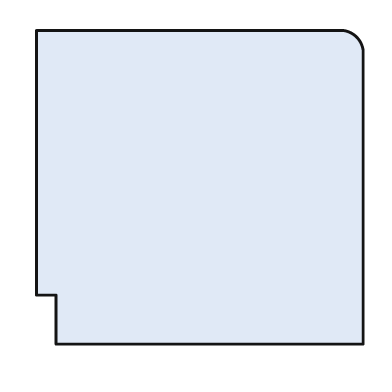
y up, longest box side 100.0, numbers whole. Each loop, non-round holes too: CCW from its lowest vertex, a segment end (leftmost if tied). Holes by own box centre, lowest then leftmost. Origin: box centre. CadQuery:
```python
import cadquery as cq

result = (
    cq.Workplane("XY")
    .moveTo(-44.0, -48.0)
    .lineTo(50.0, -48.0)
    .lineTo(50.0, 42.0)
    .threePointArc((48.0, 46.0), (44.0, 48.0))
    .lineTo(-50.0, 48.0)
    .lineTo(-50.0, -33.0)
    .lineTo(-44.0, -33.0)
    .close()
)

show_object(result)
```